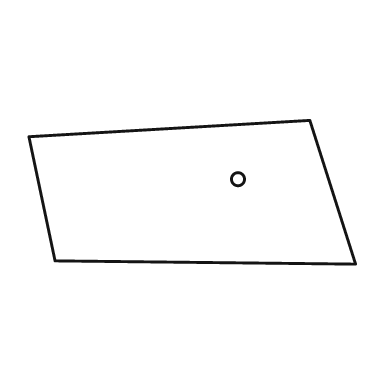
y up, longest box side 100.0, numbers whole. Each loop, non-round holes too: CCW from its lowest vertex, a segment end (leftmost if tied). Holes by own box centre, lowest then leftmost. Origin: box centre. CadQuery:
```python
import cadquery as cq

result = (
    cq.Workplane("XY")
    .moveTo(50.0, -22.0)
    .lineTo(36.0, 22.0)
    .lineTo(-50.0, 17.0)
    .lineTo(-42.0, -21.0)
    .close()
    .moveTo(14.0, 4.0)
    .circle(2.0)
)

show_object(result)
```